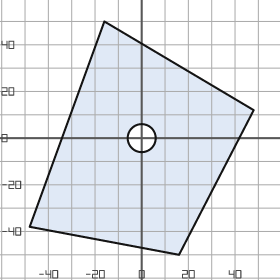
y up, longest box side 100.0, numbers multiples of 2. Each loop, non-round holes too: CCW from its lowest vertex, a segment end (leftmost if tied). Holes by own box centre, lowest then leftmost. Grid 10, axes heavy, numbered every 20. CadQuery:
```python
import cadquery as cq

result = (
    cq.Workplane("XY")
    .moveTo(16.0, -50.0)
    .lineTo(48.0, 12.0)
    .lineTo(-16.0, 50.0)
    .lineTo(-48.0, -38.0)
    .close()
    .moveTo(0.0, 0.0)
    .circle(6.0)
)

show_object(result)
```